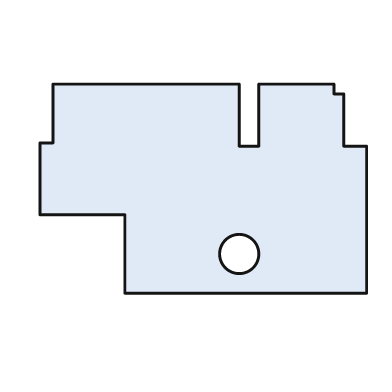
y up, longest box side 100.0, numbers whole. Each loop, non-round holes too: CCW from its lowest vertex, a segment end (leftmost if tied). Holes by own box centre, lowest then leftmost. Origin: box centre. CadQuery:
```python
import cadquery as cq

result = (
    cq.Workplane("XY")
    .moveTo(-24.0, -32.0)
    .lineTo(50.0, -32.0)
    .lineTo(50.0, 13.0)
    .lineTo(43.0, 13.0)
    .lineTo(43.0, 29.0)
    .lineTo(40.0, 29.0)
    .lineTo(40.0, 32.0)
    .lineTo(17.0, 32.0)
    .lineTo(17.0, 13.0)
    .lineTo(11.0, 13.0)
    .lineTo(11.0, 32.0)
    .lineTo(-46.0, 32.0)
    .lineTo(-46.0, 14.0)
    .lineTo(-50.0, 14.0)
    .lineTo(-50.0, -8.0)
    .lineTo(-24.0, -8.0)
    .close()
    .moveTo(11.0, -20.0)
    .circle(6.0)
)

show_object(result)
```